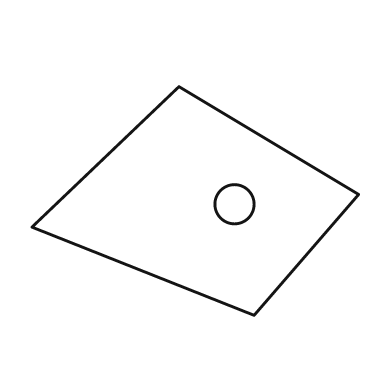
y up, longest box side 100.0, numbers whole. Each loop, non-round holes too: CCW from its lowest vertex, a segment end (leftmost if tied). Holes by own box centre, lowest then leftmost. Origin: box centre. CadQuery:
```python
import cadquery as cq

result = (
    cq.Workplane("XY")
    .moveTo(18.0, -35.0)
    .lineTo(50.0, 2.0)
    .lineTo(-5.0, 35.0)
    .lineTo(-50.0, -8.0)
    .close()
    .moveTo(12.0, -1.0)
    .circle(6.0)
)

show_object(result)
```